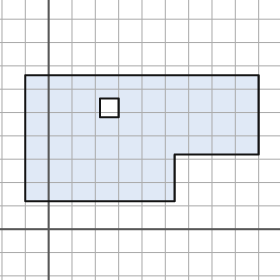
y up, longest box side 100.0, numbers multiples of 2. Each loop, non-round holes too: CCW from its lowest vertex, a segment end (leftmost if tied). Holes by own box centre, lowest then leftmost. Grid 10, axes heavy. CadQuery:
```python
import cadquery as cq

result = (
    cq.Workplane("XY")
    .moveTo(-10.0, 12.0)
    .lineTo(54.0, 12.0)
    .lineTo(54.0, 32.0)
    .lineTo(90.0, 32.0)
    .lineTo(90.0, 66.0)
    .lineTo(-10.0, 66.0)
    .close()
    .moveTo(22.0, 48.0)
    .lineTo(30.0, 48.0)
    .lineTo(30.0, 56.0)
    .lineTo(22.0, 56.0)
    .close()
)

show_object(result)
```